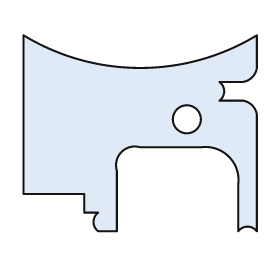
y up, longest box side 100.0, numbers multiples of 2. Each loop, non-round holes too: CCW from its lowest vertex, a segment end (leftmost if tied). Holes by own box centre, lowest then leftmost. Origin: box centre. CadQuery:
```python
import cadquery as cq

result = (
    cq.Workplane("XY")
    .moveTo(-18.0, -42.0)
    .lineTo(-10.0, -42.0)
    .lineTo(-10.0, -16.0)
    .threePointArc((-8.0, -8.0), (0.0, -6.0))
    .lineTo(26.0, -6.0)
    .threePointArc((38.0, -10.0), (42.0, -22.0))
    .lineTo(42.0, -42.0)
    .threePointArc((46.0, -40.0), (50.0, -42.0))
    .lineTo(50.0, 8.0)
    .threePointArc((48.0, 12.0), (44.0, 14.0))
    .lineTo(34.0, 14.0)
    .threePointArc((36.0, 18.0), (34.0, 22.0))
    .lineTo(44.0, 22.0)
    .threePointArc((48.0, 24.0), (50.0, 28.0))
    .lineTo(50.0, 42.0)
    .threePointArc((0.0, 28.0), (-50.0, 42.0))
    .lineTo(-50.0, -26.0)
    .lineTo(-24.0, -26.0)
    .lineTo(-24.0, -34.0)
    .lineTo(-18.0, -34.0)
    .threePointArc((-20.0, -38.0), (-18.0, -42.0))
    .close()
    .moveTo(20.0, 6.0)
    .circle(6.0)
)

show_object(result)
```